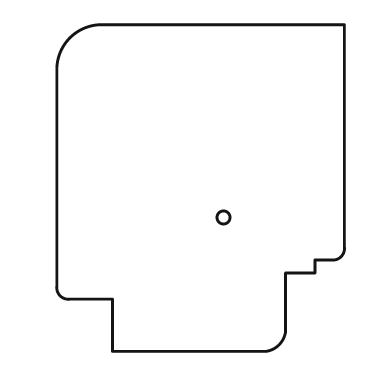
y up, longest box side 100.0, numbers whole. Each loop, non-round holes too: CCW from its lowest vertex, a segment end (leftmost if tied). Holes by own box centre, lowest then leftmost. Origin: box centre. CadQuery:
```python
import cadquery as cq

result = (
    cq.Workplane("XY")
    .moveTo(-27.0, -50.0)
    .lineTo(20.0, -50.0)
    .threePointArc((24.0, -48.0), (26.0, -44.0))
    .lineTo(26.0, -26.0)
    .lineTo(35.0, -26.0)
    .lineTo(35.0, -22.0)
    .lineTo(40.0, -22.0)
    .threePointArc((43.0, -21.0), (44.0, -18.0))
    .lineTo(44.0, 50.0)
    .lineTo(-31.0, 50.0)
    .threePointArc((-40.0, 46.0), (-44.0, 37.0))
    .lineTo(-44.0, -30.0)
    .threePointArc((-43.0, -33.0), (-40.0, -34.0))
    .lineTo(-27.0, -34.0)
    .close()
    .moveTo(7.0, -9.0)
    .circle(2.0)
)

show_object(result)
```